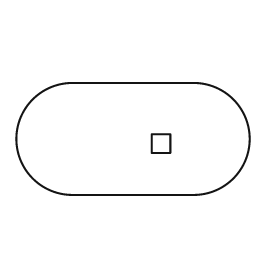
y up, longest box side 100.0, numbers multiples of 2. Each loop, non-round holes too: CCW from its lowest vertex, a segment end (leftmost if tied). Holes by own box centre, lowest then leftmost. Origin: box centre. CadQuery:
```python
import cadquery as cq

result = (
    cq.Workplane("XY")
    .moveTo(-26.0, -24.0)
    .lineTo(26.0, -24.0)
    .threePointArc((50.0, 0.0), (26.0, 24.0))
    .lineTo(-26.0, 24.0)
    .threePointArc((-50.0, 0.0), (-26.0, -24.0))
    .close()
    .moveTo(8.0, -6.0)
    .lineTo(16.0, -6.0)
    .lineTo(16.0, 2.0)
    .lineTo(8.0, 2.0)
    .close()
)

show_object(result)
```